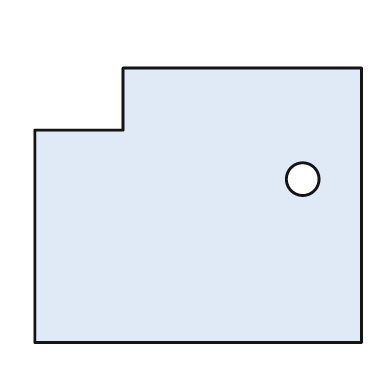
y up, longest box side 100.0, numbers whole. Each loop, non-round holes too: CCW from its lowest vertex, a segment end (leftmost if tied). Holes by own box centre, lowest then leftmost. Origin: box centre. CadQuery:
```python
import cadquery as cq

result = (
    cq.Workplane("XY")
    .moveTo(-50.0, -42.0)
    .lineTo(50.0, -42.0)
    .lineTo(50.0, 42.0)
    .lineTo(-23.0, 42.0)
    .lineTo(-23.0, 23.0)
    .lineTo(-50.0, 23.0)
    .close()
    .moveTo(32.0, 8.0)
    .circle(5.0)
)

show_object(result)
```